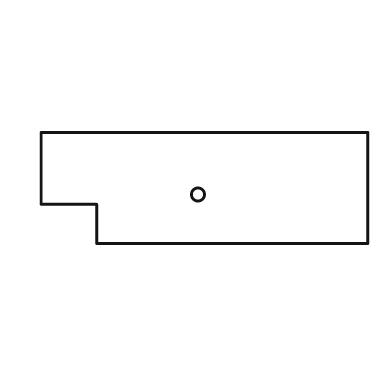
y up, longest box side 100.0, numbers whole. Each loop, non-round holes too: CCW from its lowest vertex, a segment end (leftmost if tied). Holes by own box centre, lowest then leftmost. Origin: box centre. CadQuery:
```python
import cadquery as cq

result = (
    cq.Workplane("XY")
    .moveTo(-33.0, -17.0)
    .lineTo(50.0, -17.0)
    .lineTo(50.0, 17.0)
    .lineTo(-50.0, 17.0)
    .lineTo(-50.0, -5.0)
    .lineTo(-33.0, -5.0)
    .close()
    .moveTo(-2.0, -2.0)
    .circle(2.0)
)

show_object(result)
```